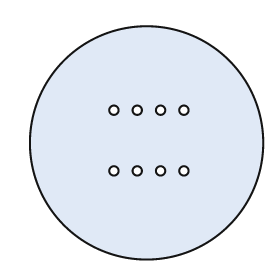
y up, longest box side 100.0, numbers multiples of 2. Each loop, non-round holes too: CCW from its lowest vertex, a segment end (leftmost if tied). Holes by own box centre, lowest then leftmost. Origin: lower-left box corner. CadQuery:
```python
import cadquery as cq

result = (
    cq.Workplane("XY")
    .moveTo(50.0, 50.0)
    .circle(50.0)
    .moveTo(36.0, 38.0)
    .circle(2.0)
    .moveTo(46.0, 38.0)
    .circle(2.0)
    .moveTo(56.0, 38.0)
    .circle(2.0)
    .moveTo(66.0, 38.0)
    .circle(2.0)
    .moveTo(36.0, 64.0)
    .circle(2.0)
    .moveTo(46.0, 64.0)
    .circle(2.0)
    .moveTo(56.0, 64.0)
    .circle(2.0)
    .moveTo(66.0, 64.0)
    .circle(2.0)
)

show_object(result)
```